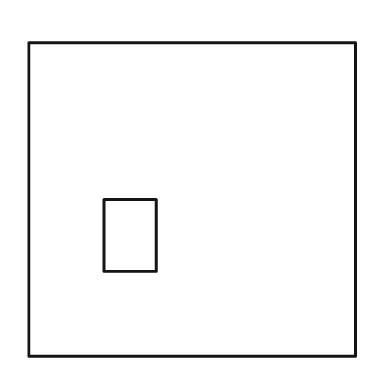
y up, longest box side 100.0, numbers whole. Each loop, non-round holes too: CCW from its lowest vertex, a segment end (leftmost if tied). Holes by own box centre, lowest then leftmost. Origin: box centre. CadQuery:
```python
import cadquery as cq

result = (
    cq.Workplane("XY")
    .moveTo(-50.0, -48.0)
    .lineTo(50.0, -48.0)
    .lineTo(50.0, 48.0)
    .lineTo(-50.0, 48.0)
    .close()
    .moveTo(-27.0, -22.0)
    .lineTo(-11.0, -22.0)
    .lineTo(-11.0, 0.0)
    .lineTo(-27.0, 0.0)
    .close()
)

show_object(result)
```